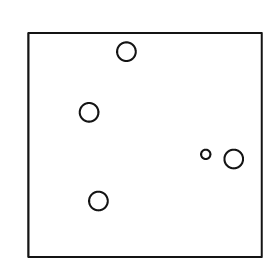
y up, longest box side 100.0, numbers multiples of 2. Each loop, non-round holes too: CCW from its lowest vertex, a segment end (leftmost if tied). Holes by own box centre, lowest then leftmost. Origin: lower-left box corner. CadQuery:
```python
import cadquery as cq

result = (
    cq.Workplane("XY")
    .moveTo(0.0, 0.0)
    .lineTo(100.0, 0.0)
    .lineTo(100.0, 96.0)
    .lineTo(0.0, 96.0)
    .close()
    .moveTo(30.0, 24.0)
    .circle(4.0)
    .moveTo(88.0, 42.0)
    .circle(4.0)
    .moveTo(76.0, 44.0)
    .circle(2.0)
    .moveTo(26.0, 62.0)
    .circle(4.0)
    .moveTo(42.0, 88.0)
    .circle(4.0)
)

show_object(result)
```